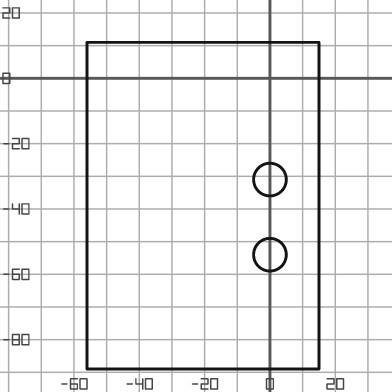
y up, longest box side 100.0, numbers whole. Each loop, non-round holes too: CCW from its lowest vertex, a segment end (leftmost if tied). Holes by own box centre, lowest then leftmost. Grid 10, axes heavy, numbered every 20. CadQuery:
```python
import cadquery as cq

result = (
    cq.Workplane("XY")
    .moveTo(-56.0, -89.0)
    .lineTo(15.0, -89.0)
    .lineTo(15.0, 11.0)
    .lineTo(-56.0, 11.0)
    .close()
    .moveTo(0.0, -54.0)
    .circle(5.0)
    .moveTo(0.0, -31.0)
    .circle(5.0)
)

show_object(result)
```